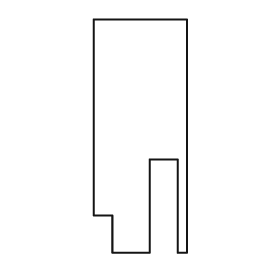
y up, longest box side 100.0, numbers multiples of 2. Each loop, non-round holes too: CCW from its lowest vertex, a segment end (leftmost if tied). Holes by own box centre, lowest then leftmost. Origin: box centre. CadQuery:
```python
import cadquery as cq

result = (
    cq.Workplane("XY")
    .moveTo(-12.0, -50.0)
    .lineTo(4.0, -50.0)
    .lineTo(4.0, -10.0)
    .lineTo(16.0, -10.0)
    .lineTo(16.0, -50.0)
    .lineTo(20.0, -50.0)
    .lineTo(20.0, 50.0)
    .lineTo(-20.0, 50.0)
    .lineTo(-20.0, -34.0)
    .lineTo(-12.0, -34.0)
    .close()
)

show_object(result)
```